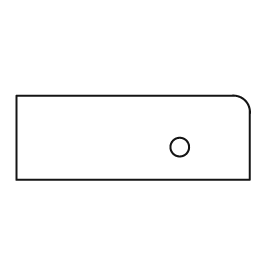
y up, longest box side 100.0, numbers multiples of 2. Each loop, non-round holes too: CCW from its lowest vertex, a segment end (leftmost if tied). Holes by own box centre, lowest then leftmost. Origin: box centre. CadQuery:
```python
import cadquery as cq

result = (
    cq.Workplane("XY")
    .moveTo(-50.0, -18.0)
    .lineTo(50.0, -18.0)
    .lineTo(50.0, 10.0)
    .threePointArc((48.0, 16.0), (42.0, 18.0))
    .lineTo(-50.0, 18.0)
    .close()
    .moveTo(20.0, -4.0)
    .circle(4.0)
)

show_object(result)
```